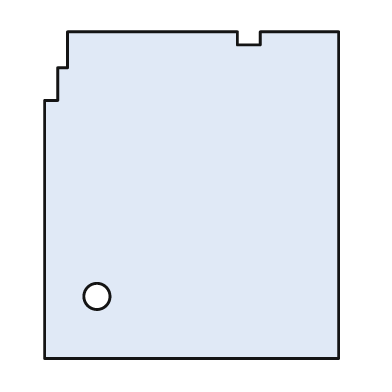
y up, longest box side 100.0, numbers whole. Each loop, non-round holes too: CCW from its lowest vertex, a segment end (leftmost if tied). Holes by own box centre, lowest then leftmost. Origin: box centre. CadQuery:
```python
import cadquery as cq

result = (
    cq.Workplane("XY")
    .moveTo(-45.0, -50.0)
    .lineTo(45.0, -50.0)
    .lineTo(45.0, 50.0)
    .lineTo(21.0, 50.0)
    .lineTo(21.0, 46.0)
    .lineTo(14.0, 46.0)
    .lineTo(14.0, 50.0)
    .lineTo(-38.0, 50.0)
    .lineTo(-38.0, 39.0)
    .lineTo(-41.0, 39.0)
    .lineTo(-41.0, 29.0)
    .lineTo(-45.0, 29.0)
    .close()
    .moveTo(-29.0, -31.0)
    .circle(4.0)
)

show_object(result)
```